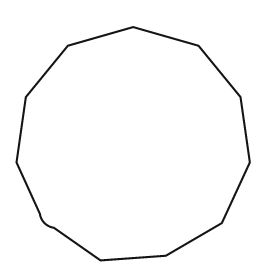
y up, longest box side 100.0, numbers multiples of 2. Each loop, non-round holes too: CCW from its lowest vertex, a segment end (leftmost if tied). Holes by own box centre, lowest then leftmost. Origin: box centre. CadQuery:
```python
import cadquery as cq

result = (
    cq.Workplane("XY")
    .moveTo(-14.0, -50.0)
    .lineTo(14.0, -48.0)
    .lineTo(38.0, -34.0)
    .lineTo(50.0, -8.0)
    .lineTo(46.0, 20.0)
    .lineTo(28.0, 42.0)
    .lineTo(0.0, 50.0)
    .lineTo(-28.0, 42.0)
    .lineTo(-46.0, 20.0)
    .lineTo(-50.0, -8.0)
    .lineTo(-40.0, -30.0)
    .threePointArc((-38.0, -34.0), (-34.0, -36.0))
    .close()
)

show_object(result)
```